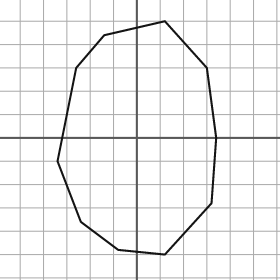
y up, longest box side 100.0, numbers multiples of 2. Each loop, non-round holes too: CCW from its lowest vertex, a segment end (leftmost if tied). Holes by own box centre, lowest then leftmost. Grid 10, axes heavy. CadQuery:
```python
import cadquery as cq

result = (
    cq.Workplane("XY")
    .moveTo(12.0, -50.0)
    .lineTo(32.0, -28.0)
    .lineTo(34.0, 0.0)
    .lineTo(30.0, 30.0)
    .lineTo(12.0, 50.0)
    .lineTo(-14.0, 44.0)
    .lineTo(-26.0, 30.0)
    .lineTo(-34.0, -10.0)
    .lineTo(-24.0, -36.0)
    .lineTo(-8.0, -48.0)
    .close()
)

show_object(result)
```